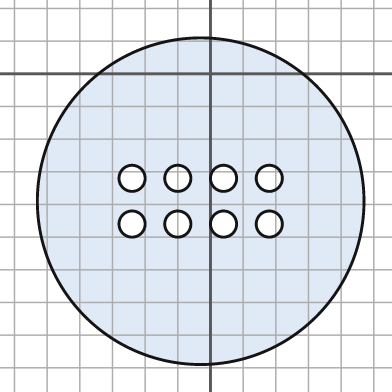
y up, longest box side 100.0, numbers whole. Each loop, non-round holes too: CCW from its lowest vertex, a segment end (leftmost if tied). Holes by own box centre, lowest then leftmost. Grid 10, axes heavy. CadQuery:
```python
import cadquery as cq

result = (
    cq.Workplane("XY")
    .moveTo(-3.0, -39.0)
    .circle(50.0)
    .moveTo(-24.0, -46.0)
    .circle(4.0)
    .moveTo(-10.0, -46.0)
    .circle(4.0)
    .moveTo(4.0, -46.0)
    .circle(4.0)
    .moveTo(18.0, -46.0)
    .circle(4.0)
    .moveTo(-24.0, -32.0)
    .circle(4.0)
    .moveTo(-10.0, -32.0)
    .circle(4.0)
    .moveTo(4.0, -32.0)
    .circle(4.0)
    .moveTo(18.0, -32.0)
    .circle(4.0)
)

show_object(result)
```